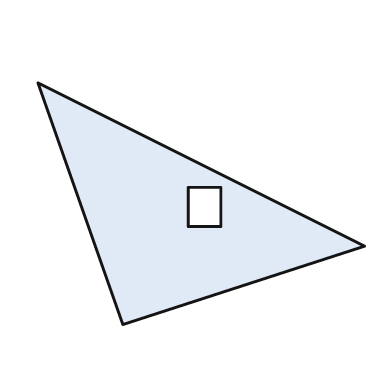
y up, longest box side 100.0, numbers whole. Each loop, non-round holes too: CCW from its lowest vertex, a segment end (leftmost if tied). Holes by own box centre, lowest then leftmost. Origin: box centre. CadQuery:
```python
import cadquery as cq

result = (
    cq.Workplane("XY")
    .moveTo(-24.0, -37.0)
    .lineTo(50.0, -13.0)
    .lineTo(-50.0, 37.0)
    .close()
    .moveTo(-4.0, -7.0)
    .lineTo(6.0, -7.0)
    .lineTo(6.0, 5.0)
    .lineTo(-4.0, 5.0)
    .close()
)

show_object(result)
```